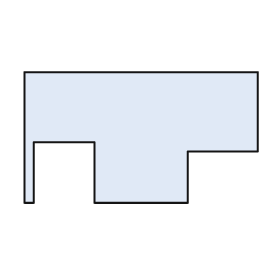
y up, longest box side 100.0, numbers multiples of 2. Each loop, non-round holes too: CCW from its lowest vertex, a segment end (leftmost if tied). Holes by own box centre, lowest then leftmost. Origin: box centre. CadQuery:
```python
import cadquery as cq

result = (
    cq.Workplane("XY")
    .moveTo(-50.0, -28.0)
    .lineTo(-46.0, -28.0)
    .lineTo(-46.0, -2.0)
    .lineTo(-20.0, -2.0)
    .lineTo(-20.0, -28.0)
    .lineTo(20.0, -28.0)
    .lineTo(20.0, -6.0)
    .lineTo(50.0, -6.0)
    .lineTo(50.0, 28.0)
    .lineTo(-50.0, 28.0)
    .close()
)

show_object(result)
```